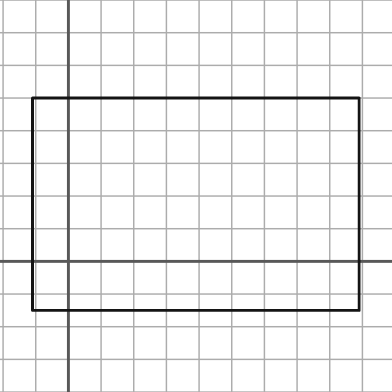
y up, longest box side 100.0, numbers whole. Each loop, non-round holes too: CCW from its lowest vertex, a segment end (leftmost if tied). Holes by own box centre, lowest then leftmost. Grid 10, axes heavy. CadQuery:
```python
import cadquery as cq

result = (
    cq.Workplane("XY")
    .moveTo(-11.0, -15.0)
    .lineTo(89.0, -15.0)
    .lineTo(89.0, 50.0)
    .lineTo(-11.0, 50.0)
    .close()
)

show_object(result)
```